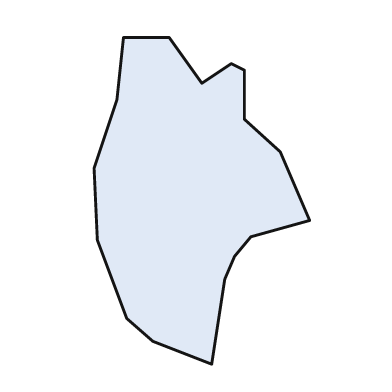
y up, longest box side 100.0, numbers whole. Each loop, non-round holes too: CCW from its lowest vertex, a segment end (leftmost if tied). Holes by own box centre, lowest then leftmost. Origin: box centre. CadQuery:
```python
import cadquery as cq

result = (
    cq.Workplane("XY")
    .moveTo(3.0, -50.0)
    .lineTo(7.0, -24.0)
    .lineTo(10.0, -17.0)
    .lineTo(15.0, -11.0)
    .lineTo(33.0, -6.0)
    .lineTo(24.0, 15.0)
    .lineTo(13.0, 25.0)
    .lineTo(13.0, 40.0)
    .lineTo(9.0, 42.0)
    .lineTo(0.0, 36.0)
    .lineTo(-10.0, 50.0)
    .lineTo(-24.0, 50.0)
    .lineTo(-26.0, 31.0)
    .lineTo(-33.0, 10.0)
    .lineTo(-32.0, -12.0)
    .lineTo(-23.0, -36.0)
    .lineTo(-15.0, -43.0)
    .close()
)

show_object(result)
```